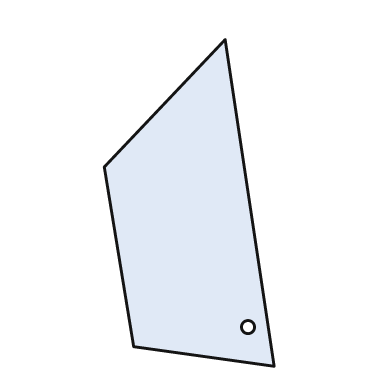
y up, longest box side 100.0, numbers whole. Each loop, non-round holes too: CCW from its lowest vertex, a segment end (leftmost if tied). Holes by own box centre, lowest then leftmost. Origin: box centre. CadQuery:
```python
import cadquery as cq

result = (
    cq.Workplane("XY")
    .moveTo(26.0, -50.0)
    .lineTo(11.0, 50.0)
    .lineTo(-26.0, 11.0)
    .lineTo(-17.0, -44.0)
    .close()
    .moveTo(18.0, -38.0)
    .circle(2.0)
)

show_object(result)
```